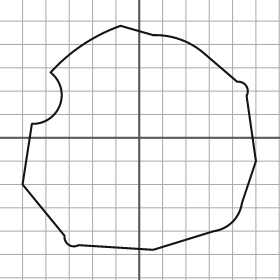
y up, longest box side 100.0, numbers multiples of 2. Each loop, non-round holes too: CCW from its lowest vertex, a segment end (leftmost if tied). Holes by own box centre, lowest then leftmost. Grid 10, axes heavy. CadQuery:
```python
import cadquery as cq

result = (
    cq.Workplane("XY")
    .moveTo(6.0, -48.0)
    .lineTo(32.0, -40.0)
    .threePointArc((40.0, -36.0), (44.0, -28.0))
    .lineTo(50.0, -10.0)
    .lineTo(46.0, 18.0)
    .threePointArc((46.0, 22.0), (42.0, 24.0))
    .lineTo(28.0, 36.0)
    .threePointArc((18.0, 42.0), (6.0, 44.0))
    .lineTo(-8.0, 48.0)
    .threePointArc((-24.0, 40.0), (-38.0, 28.0))
    .threePointArc((-34.0, 14.0), (-46.0, 6.0))
    .lineTo(-50.0, -20.0)
    .lineTo(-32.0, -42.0)
    .threePointArc((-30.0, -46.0), (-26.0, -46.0))
    .close()
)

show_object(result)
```